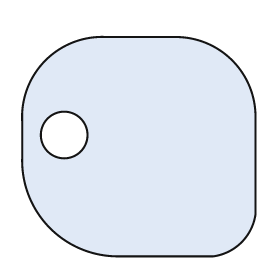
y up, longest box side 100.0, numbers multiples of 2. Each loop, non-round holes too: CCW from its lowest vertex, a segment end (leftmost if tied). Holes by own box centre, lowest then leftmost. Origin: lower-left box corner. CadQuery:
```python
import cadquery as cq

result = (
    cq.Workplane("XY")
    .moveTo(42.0, 0.0)
    .lineTo(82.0, 0.0)
    .threePointArc((94.0, 6.0), (100.0, 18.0))
    .lineTo(100.0, 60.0)
    .threePointArc((90.0, 84.0), (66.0, 94.0))
    .lineTo(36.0, 94.0)
    .threePointArc((10.0, 84.0), (0.0, 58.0))
    .lineTo(0.0, 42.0)
    .threePointArc((12.0, 12.0), (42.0, 0.0))
    .close()
    .moveTo(18.0, 52.0)
    .circle(10.0)
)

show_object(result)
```